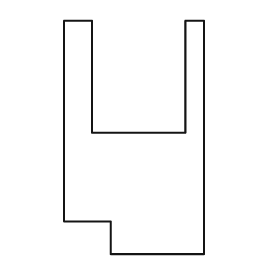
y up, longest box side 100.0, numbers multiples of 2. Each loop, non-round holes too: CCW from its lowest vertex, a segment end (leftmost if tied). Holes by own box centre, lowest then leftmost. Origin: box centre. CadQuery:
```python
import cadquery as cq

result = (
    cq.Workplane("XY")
    .moveTo(-10.0, -50.0)
    .lineTo(30.0, -50.0)
    .lineTo(30.0, 50.0)
    .lineTo(22.0, 50.0)
    .lineTo(22.0, 2.0)
    .lineTo(-18.0, 2.0)
    .lineTo(-18.0, 50.0)
    .lineTo(-30.0, 50.0)
    .lineTo(-30.0, -36.0)
    .lineTo(-10.0, -36.0)
    .close()
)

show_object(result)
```